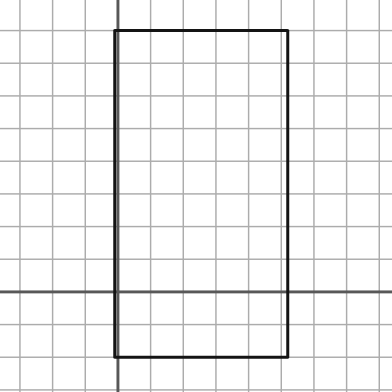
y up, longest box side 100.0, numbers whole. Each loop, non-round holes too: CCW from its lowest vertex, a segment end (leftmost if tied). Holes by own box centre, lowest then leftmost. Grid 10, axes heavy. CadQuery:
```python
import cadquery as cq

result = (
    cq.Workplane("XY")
    .moveTo(-1.0, -20.0)
    .lineTo(52.0, -20.0)
    .lineTo(52.0, 80.0)
    .lineTo(-1.0, 80.0)
    .close()
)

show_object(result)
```